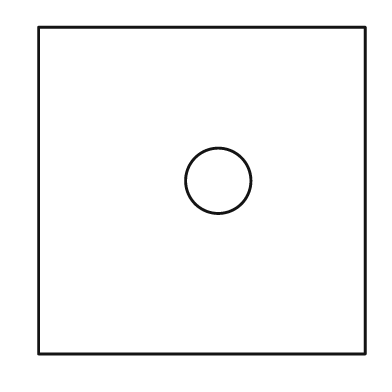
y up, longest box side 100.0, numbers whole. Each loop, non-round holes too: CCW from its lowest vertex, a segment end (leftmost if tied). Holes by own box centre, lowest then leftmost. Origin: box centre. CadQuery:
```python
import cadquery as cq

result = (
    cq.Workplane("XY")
    .moveTo(-50.0, -50.0)
    .lineTo(50.0, -50.0)
    .lineTo(50.0, 50.0)
    .lineTo(-50.0, 50.0)
    .close()
    .moveTo(5.0, 3.0)
    .circle(10.0)
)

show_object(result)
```